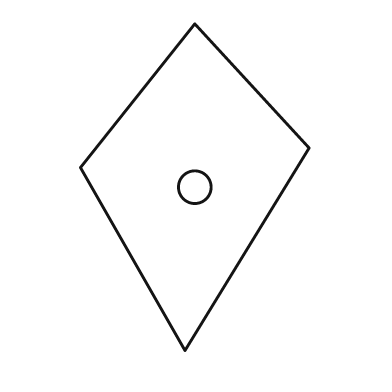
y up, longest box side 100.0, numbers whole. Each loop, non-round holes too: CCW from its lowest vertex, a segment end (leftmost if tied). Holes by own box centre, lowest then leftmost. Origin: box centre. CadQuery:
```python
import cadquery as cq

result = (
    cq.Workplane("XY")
    .moveTo(-3.0, -50.0)
    .lineTo(35.0, 12.0)
    .lineTo(0.0, 50.0)
    .lineTo(-35.0, 6.0)
    .close()
    .moveTo(0.0, 0.0)
    .circle(5.0)
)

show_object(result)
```